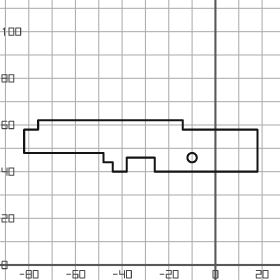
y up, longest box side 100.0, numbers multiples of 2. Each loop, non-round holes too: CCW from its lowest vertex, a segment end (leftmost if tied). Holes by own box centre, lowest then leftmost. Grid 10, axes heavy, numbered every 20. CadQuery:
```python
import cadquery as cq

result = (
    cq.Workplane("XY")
    .moveTo(-44.0, 40.0)
    .lineTo(-38.0, 40.0)
    .lineTo(-38.0, 46.0)
    .lineTo(-26.0, 46.0)
    .lineTo(-26.0, 40.0)
    .lineTo(18.0, 40.0)
    .lineTo(18.0, 58.0)
    .lineTo(-14.0, 58.0)
    .lineTo(-14.0, 62.0)
    .lineTo(-76.0, 62.0)
    .lineTo(-76.0, 58.0)
    .lineTo(-82.0, 58.0)
    .lineTo(-82.0, 48.0)
    .lineTo(-48.0, 48.0)
    .lineTo(-48.0, 44.0)
    .lineTo(-44.0, 44.0)
    .close()
    .moveTo(-10.0, 46.0)
    .circle(2.0)
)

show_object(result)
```